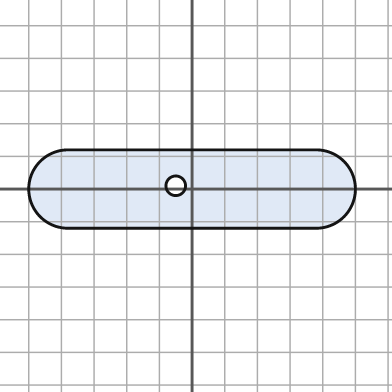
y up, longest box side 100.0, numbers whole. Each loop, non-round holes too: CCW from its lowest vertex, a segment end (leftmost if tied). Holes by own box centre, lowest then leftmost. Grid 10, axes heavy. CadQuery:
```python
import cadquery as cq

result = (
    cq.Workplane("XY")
    .moveTo(-38.0, -12.0)
    .lineTo(38.0, -12.0)
    .threePointArc((50.0, 0.0), (38.0, 12.0))
    .lineTo(-38.0, 12.0)
    .threePointArc((-50.0, 0.0), (-38.0, -12.0))
    .close()
    .moveTo(-5.0, 1.0)
    .circle(3.0)
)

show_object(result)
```